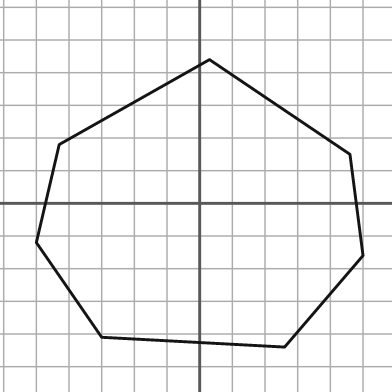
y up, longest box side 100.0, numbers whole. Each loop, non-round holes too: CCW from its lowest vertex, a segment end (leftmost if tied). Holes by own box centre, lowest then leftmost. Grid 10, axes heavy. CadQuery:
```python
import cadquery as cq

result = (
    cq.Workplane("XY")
    .moveTo(26.0, -44.0)
    .lineTo(50.0, -16.0)
    .lineTo(46.0, 15.0)
    .lineTo(3.0, 44.0)
    .lineTo(-43.0, 18.0)
    .lineTo(-50.0, -12.0)
    .lineTo(-30.0, -41.0)
    .close()
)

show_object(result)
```